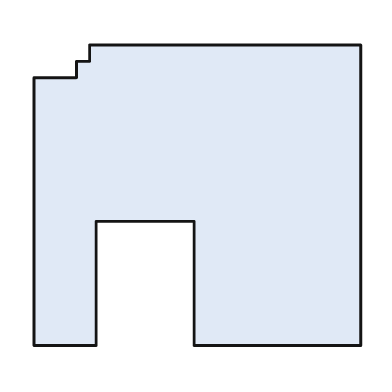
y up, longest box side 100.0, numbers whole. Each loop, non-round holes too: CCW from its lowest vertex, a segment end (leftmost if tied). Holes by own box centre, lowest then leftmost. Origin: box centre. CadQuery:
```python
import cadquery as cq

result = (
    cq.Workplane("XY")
    .moveTo(-50.0, -46.0)
    .lineTo(-31.0, -46.0)
    .lineTo(-31.0, -8.0)
    .lineTo(-1.0, -8.0)
    .lineTo(-1.0, -46.0)
    .lineTo(50.0, -46.0)
    .lineTo(50.0, 46.0)
    .lineTo(-33.0, 46.0)
    .lineTo(-33.0, 41.0)
    .lineTo(-37.0, 41.0)
    .lineTo(-37.0, 36.0)
    .lineTo(-50.0, 36.0)
    .close()
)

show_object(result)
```